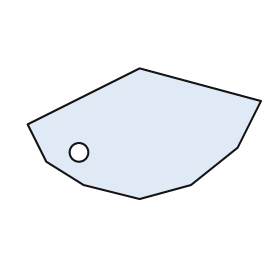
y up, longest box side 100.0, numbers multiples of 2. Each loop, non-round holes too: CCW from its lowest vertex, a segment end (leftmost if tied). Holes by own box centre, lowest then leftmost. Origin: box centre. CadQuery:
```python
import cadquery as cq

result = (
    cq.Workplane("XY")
    .moveTo(-2.0, -28.0)
    .lineTo(20.0, -22.0)
    .lineTo(40.0, -6.0)
    .lineTo(50.0, 14.0)
    .lineTo(-2.0, 28.0)
    .lineTo(-50.0, 4.0)
    .lineTo(-42.0, -12.0)
    .lineTo(-26.0, -22.0)
    .close()
    .moveTo(-28.0, -8.0)
    .circle(4.0)
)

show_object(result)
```